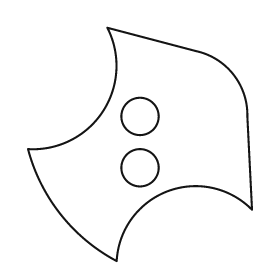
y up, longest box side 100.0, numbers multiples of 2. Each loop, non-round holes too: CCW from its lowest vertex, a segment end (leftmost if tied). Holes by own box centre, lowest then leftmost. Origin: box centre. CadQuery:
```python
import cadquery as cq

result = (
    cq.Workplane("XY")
    .moveTo(-10.0, -50.0)
    .threePointArc((12.0, -20.0), (48.0, -28.0))
    .lineTo(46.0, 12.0)
    .threePointArc((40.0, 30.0), (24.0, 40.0))
    .lineTo(-14.0, 50.0)
    .threePointArc((-16.0, 14.0), (-48.0, -2.0))
    .threePointArc((-34.0, -30.0), (-10.0, -50.0))
    .close()
    .moveTo(0.0, -10.0)
    .circle(8.0)
    .moveTo(0.0, 12.0)
    .circle(8.0)
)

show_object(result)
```